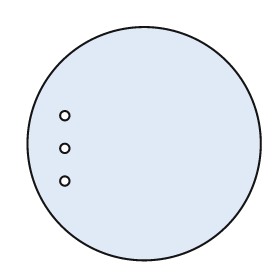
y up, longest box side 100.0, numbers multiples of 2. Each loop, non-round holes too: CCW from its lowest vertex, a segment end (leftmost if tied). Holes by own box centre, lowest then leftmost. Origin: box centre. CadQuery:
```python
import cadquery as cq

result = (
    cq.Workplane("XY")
    .moveTo(0.0, 0.0)
    .circle(50.0)
    .moveTo(-34.0, -16.0)
    .circle(2.0)
    .moveTo(-34.0, -2.0)
    .circle(2.0)
    .moveTo(-34.0, 12.0)
    .circle(2.0)
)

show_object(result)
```